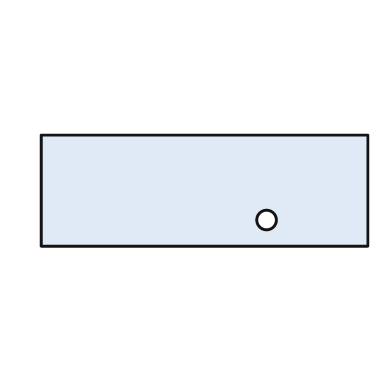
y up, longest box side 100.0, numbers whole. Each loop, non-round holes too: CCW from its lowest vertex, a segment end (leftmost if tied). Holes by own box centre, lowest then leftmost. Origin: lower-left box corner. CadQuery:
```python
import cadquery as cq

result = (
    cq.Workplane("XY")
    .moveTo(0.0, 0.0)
    .lineTo(100.0, 0.0)
    .lineTo(100.0, 34.0)
    .lineTo(0.0, 34.0)
    .close()
    .moveTo(69.0, 8.0)
    .circle(3.0)
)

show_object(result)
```